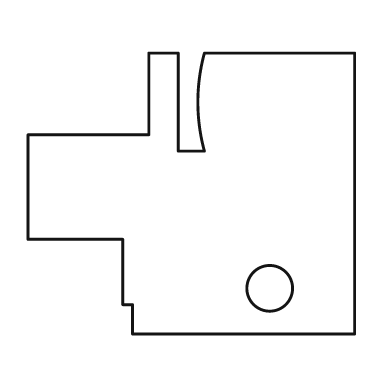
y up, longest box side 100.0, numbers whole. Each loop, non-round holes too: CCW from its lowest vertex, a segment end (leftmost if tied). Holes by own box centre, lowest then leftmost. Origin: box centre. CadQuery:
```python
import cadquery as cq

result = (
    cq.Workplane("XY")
    .moveTo(-18.0, -43.0)
    .lineTo(50.0, -43.0)
    .lineTo(50.0, 43.0)
    .lineTo(4.0, 43.0)
    .threePointArc((2.0, 28.0), (4.0, 13.0))
    .lineTo(-4.0, 13.0)
    .lineTo(-4.0, 43.0)
    .lineTo(-13.0, 43.0)
    .lineTo(-13.0, 18.0)
    .lineTo(-50.0, 18.0)
    .lineTo(-50.0, -14.0)
    .lineTo(-21.0, -14.0)
    .lineTo(-21.0, -34.0)
    .lineTo(-18.0, -34.0)
    .close()
    .moveTo(24.0, -29.0)
    .circle(7.0)
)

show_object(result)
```